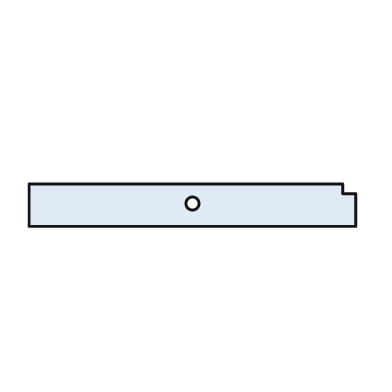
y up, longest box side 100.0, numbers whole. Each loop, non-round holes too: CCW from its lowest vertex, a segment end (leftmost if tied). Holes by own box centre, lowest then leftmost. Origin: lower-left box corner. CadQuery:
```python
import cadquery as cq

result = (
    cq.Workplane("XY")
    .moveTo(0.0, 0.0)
    .lineTo(100.0, 0.0)
    .lineTo(100.0, 10.0)
    .lineTo(96.0, 10.0)
    .lineTo(96.0, 13.0)
    .lineTo(0.0, 13.0)
    .close()
    .moveTo(50.0, 7.0)
    .circle(2.0)
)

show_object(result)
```